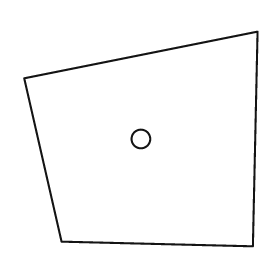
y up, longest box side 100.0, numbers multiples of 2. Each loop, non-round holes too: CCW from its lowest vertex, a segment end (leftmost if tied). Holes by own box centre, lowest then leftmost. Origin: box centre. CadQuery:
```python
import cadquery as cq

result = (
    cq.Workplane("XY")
    .moveTo(48.0, -46.0)
    .lineTo(50.0, 46.0)
    .lineTo(-50.0, 26.0)
    .lineTo(-34.0, -44.0)
    .close()
    .moveTo(0.0, 0.0)
    .circle(4.0)
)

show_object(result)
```